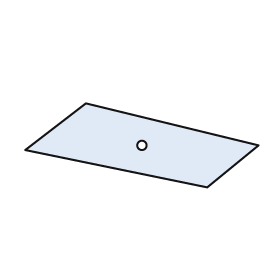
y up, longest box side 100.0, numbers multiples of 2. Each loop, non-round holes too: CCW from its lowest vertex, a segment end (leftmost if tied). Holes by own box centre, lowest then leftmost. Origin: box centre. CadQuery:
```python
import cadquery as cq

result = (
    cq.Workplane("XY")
    .moveTo(28.0, -18.0)
    .lineTo(50.0, 0.0)
    .lineTo(-24.0, 18.0)
    .lineTo(-50.0, -2.0)
    .close()
    .moveTo(0.0, 0.0)
    .circle(2.0)
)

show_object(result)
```